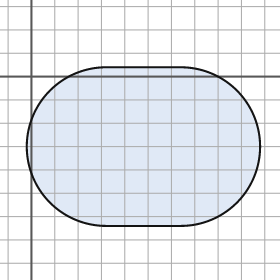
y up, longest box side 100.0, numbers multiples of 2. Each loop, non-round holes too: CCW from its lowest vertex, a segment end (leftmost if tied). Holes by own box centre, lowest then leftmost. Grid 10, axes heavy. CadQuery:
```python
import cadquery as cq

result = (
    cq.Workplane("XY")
    .moveTo(32.0, -64.0)
    .lineTo(64.0, -64.0)
    .threePointArc((98.0, -30.0), (64.0, 4.0))
    .lineTo(32.0, 4.0)
    .threePointArc((-2.0, -30.0), (32.0, -64.0))
    .close()
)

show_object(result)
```